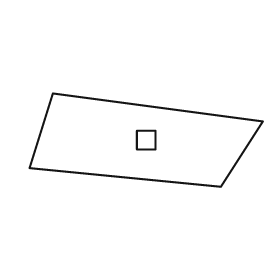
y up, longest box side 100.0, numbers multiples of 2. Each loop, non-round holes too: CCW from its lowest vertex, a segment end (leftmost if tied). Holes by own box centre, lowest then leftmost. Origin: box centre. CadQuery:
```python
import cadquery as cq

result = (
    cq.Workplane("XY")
    .moveTo(32.0, -20.0)
    .lineTo(50.0, 8.0)
    .lineTo(-40.0, 20.0)
    .lineTo(-50.0, -12.0)
    .close()
    .moveTo(-4.0, -4.0)
    .lineTo(4.0, -4.0)
    .lineTo(4.0, 4.0)
    .lineTo(-4.0, 4.0)
    .close()
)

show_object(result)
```